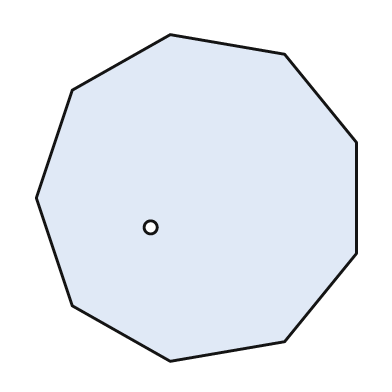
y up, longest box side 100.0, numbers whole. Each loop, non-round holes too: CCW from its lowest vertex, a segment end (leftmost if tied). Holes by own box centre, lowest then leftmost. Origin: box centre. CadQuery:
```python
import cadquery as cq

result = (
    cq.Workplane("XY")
    .moveTo(-8.0, -50.0)
    .lineTo(27.0, -44.0)
    .lineTo(49.0, -17.0)
    .lineTo(49.0, 17.0)
    .lineTo(27.0, 44.0)
    .lineTo(-8.0, 50.0)
    .lineTo(-38.0, 33.0)
    .lineTo(-49.0, 0.0)
    .lineTo(-38.0, -33.0)
    .close()
    .moveTo(-14.0, -9.0)
    .circle(2.0)
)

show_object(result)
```